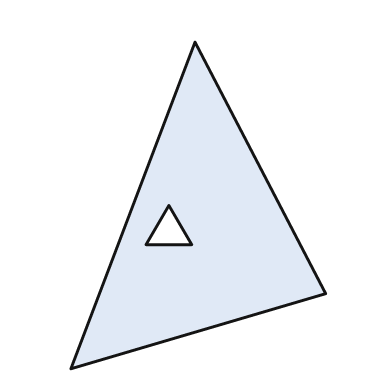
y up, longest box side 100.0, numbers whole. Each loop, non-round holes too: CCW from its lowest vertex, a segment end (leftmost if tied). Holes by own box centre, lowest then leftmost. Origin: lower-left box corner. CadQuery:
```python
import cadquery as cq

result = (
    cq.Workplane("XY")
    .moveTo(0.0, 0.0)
    .lineTo(78.0, 23.0)
    .lineTo(38.0, 100.0)
    .close()
    .moveTo(23.0, 38.0)
    .lineTo(37.0, 38.0)
    .lineTo(30.0, 50.0)
    .close()
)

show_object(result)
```